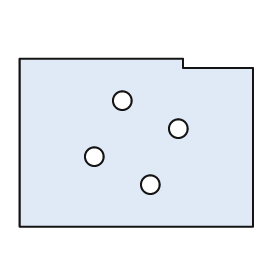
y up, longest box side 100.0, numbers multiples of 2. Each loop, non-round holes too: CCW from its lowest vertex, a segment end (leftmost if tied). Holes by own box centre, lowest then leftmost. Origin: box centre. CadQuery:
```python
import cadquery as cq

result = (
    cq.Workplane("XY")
    .moveTo(-50.0, -36.0)
    .lineTo(50.0, -36.0)
    .lineTo(50.0, 32.0)
    .lineTo(20.0, 32.0)
    .lineTo(20.0, 36.0)
    .lineTo(-50.0, 36.0)
    .close()
    .moveTo(6.0, -18.0)
    .circle(4.0)
    .moveTo(-18.0, -6.0)
    .circle(4.0)
    .moveTo(18.0, 6.0)
    .circle(4.0)
    .moveTo(-6.0, 18.0)
    .circle(4.0)
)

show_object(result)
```